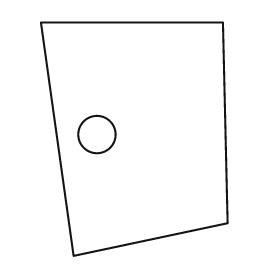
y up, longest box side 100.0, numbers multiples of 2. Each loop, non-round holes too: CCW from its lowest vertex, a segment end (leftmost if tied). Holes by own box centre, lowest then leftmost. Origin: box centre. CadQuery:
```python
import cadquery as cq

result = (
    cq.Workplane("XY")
    .moveTo(-26.0, -50.0)
    .lineTo(40.0, -36.0)
    .lineTo(38.0, 50.0)
    .lineTo(-40.0, 50.0)
    .close()
    .moveTo(-16.0, 2.0)
    .circle(8.0)
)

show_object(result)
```